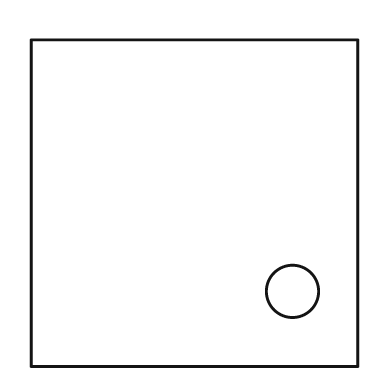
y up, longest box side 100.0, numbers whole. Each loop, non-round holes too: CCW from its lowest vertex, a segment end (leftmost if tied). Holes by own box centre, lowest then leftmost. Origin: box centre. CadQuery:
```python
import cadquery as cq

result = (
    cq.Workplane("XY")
    .moveTo(-50.0, -50.0)
    .lineTo(50.0, -50.0)
    .lineTo(50.0, 50.0)
    .lineTo(-50.0, 50.0)
    .close()
    .moveTo(30.0, -27.0)
    .circle(8.0)
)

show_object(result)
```